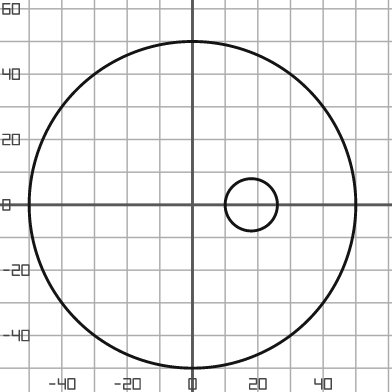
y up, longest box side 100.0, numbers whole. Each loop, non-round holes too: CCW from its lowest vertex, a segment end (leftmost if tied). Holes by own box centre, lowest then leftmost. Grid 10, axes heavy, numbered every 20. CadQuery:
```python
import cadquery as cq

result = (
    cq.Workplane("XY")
    .moveTo(0.0, 0.0)
    .circle(50.0)
    .moveTo(18.0, 0.0)
    .circle(8.0)
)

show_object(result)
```